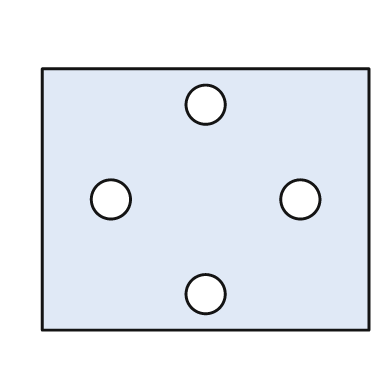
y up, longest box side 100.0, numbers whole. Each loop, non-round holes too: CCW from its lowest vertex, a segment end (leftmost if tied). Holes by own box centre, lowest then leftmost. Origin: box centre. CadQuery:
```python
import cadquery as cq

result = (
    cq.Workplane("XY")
    .moveTo(-50.0, -40.0)
    .lineTo(50.0, -40.0)
    .lineTo(50.0, 40.0)
    .lineTo(-50.0, 40.0)
    .close()
    .moveTo(0.0, -29.0)
    .circle(6.0)
    .moveTo(-29.0, 0.0)
    .circle(6.0)
    .moveTo(29.0, 0.0)
    .circle(6.0)
    .moveTo(0.0, 29.0)
    .circle(6.0)
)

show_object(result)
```